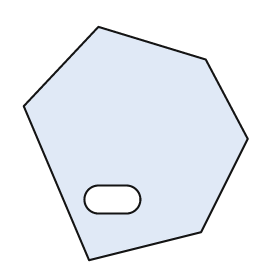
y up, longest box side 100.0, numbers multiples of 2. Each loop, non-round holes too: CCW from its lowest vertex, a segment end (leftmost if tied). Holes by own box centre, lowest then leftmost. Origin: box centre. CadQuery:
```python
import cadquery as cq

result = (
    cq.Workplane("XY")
    .moveTo(-20.0, -50.0)
    .lineTo(28.0, -38.0)
    .lineTo(48.0, 2.0)
    .lineTo(30.0, 36.0)
    .lineTo(-16.0, 50.0)
    .lineTo(-48.0, 16.0)
    .close()
    .moveTo(-16.0, -30.0)
    .lineTo(-4.0, -30.0)
    .threePointArc((2.0, -24.0), (-4.0, -18.0))
    .lineTo(-16.0, -18.0)
    .threePointArc((-22.0, -24.0), (-16.0, -30.0))
    .close()
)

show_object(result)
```